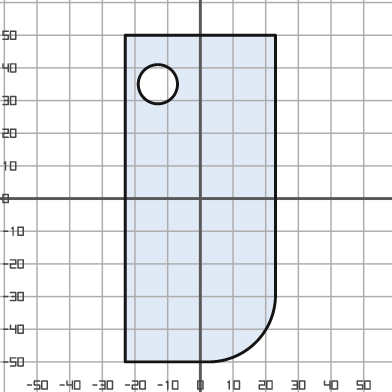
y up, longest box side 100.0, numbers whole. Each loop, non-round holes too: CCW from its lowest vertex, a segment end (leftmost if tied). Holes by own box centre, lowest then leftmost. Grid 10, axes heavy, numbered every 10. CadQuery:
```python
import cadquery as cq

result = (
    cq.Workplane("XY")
    .moveTo(-23.0, -50.0)
    .lineTo(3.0, -50.0)
    .threePointArc((17.0, -44.0), (23.0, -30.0))
    .lineTo(23.0, 50.0)
    .lineTo(-23.0, 50.0)
    .close()
    .moveTo(-13.0, 35.0)
    .circle(6.0)
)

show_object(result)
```